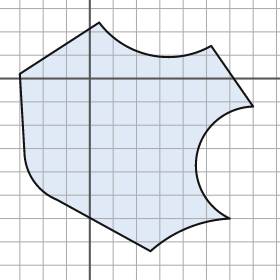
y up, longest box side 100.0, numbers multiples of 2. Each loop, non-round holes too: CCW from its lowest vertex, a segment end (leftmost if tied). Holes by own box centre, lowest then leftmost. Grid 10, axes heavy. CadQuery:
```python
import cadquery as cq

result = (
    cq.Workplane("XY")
    .moveTo(26.0, -74.0)
    .threePointArc((42.0, -64.0), (60.0, -60.0))
    .threePointArc((46.0, -32.0), (70.0, -12.0))
    .lineTo(52.0, 14.0)
    .threePointArc((26.0, 10.0), (4.0, 24.0))
    .lineTo(-30.0, 2.0)
    .lineTo(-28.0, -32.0)
    .threePointArc((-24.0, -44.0), (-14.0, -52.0))
    .close()
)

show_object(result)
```